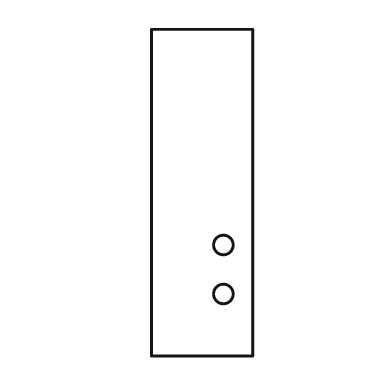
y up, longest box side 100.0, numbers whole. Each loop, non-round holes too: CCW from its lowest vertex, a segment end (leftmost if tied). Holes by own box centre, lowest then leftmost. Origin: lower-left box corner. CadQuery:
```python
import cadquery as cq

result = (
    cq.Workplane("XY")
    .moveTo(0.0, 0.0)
    .lineTo(31.0, 0.0)
    .lineTo(31.0, 100.0)
    .lineTo(0.0, 100.0)
    .close()
    .moveTo(22.0, 19.0)
    .circle(3.0)
    .moveTo(22.0, 34.0)
    .circle(3.0)
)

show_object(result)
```